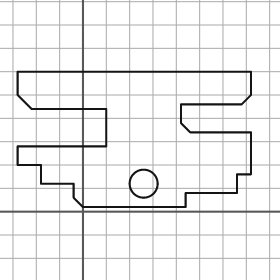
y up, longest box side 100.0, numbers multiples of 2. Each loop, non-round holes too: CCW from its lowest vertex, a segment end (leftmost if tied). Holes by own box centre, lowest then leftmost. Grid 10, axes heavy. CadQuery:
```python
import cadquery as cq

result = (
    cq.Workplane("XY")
    .moveTo(0.0, 2.0)
    .lineTo(44.0, 2.0)
    .lineTo(44.0, 8.0)
    .lineTo(66.0, 8.0)
    .lineTo(66.0, 16.0)
    .lineTo(72.0, 16.0)
    .lineTo(72.0, 34.0)
    .lineTo(46.0, 34.0)
    .lineTo(42.0, 38.0)
    .lineTo(42.0, 46.0)
    .lineTo(68.0, 46.0)
    .lineTo(72.0, 50.0)
    .lineTo(72.0, 60.0)
    .lineTo(-28.0, 60.0)
    .lineTo(-28.0, 50.0)
    .lineTo(-22.0, 44.0)
    .lineTo(10.0, 44.0)
    .lineTo(10.0, 28.0)
    .lineTo(-28.0, 28.0)
    .lineTo(-28.0, 20.0)
    .lineTo(-18.0, 20.0)
    .lineTo(-18.0, 12.0)
    .lineTo(-4.0, 12.0)
    .lineTo(-4.0, 6.0)
    .close()
    .moveTo(26.0, 12.0)
    .circle(6.0)
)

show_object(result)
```